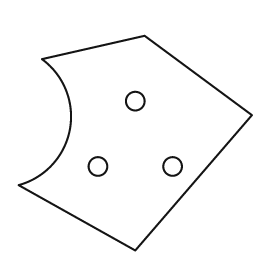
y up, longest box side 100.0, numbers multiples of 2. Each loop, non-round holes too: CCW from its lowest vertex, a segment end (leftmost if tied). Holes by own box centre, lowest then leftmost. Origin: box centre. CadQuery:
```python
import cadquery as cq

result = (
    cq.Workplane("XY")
    .moveTo(0.0, -46.0)
    .lineTo(50.0, 12.0)
    .lineTo(4.0, 46.0)
    .lineTo(-40.0, 36.0)
    .threePointArc((-28.0, 6.0), (-50.0, -18.0))
    .close()
    .moveTo(-16.0, -10.0)
    .circle(4.0)
    .moveTo(16.0, -10.0)
    .circle(4.0)
    .moveTo(0.0, 18.0)
    .circle(4.0)
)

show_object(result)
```